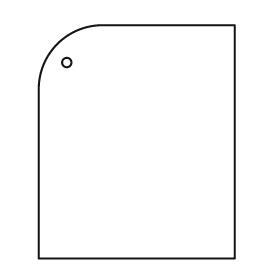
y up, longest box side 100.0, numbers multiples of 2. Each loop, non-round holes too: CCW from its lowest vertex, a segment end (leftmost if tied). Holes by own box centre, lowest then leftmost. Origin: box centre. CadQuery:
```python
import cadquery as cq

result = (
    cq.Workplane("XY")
    .moveTo(-42.0, -50.0)
    .lineTo(42.0, -50.0)
    .lineTo(42.0, 50.0)
    .lineTo(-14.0, 50.0)
    .threePointArc((-34.0, 42.0), (-42.0, 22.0))
    .close()
    .moveTo(-30.0, 34.0)
    .circle(2.0)
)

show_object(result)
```